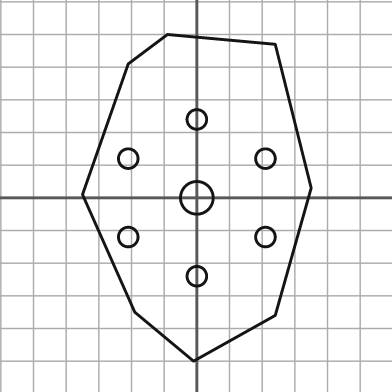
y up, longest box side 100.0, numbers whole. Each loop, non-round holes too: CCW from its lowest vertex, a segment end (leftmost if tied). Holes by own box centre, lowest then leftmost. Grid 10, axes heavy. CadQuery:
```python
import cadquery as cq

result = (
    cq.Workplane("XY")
    .moveTo(-1.0, -50.0)
    .lineTo(24.0, -36.0)
    .lineTo(35.0, 3.0)
    .lineTo(24.0, 47.0)
    .lineTo(-9.0, 50.0)
    .lineTo(-21.0, 41.0)
    .lineTo(-35.0, 1.0)
    .lineTo(-19.0, -35.0)
    .close()
    .moveTo(0.0, -24.0)
    .circle(3.0)
    .moveTo(-21.0, -12.0)
    .circle(3.0)
    .moveTo(21.0, -12.0)
    .circle(3.0)
    .moveTo(0.0, 0.0)
    .circle(5.0)
    .moveTo(-21.0, 12.0)
    .circle(3.0)
    .moveTo(21.0, 12.0)
    .circle(3.0)
    .moveTo(0.0, 24.0)
    .circle(3.0)
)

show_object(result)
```